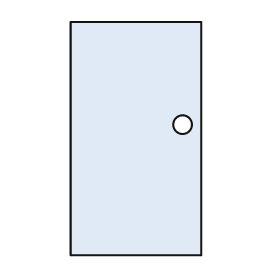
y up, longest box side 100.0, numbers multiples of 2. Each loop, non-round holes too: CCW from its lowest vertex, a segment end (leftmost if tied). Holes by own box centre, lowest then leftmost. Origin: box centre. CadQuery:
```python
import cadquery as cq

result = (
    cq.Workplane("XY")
    .moveTo(-28.0, -50.0)
    .lineTo(28.0, -50.0)
    .lineTo(28.0, 50.0)
    .lineTo(-28.0, 50.0)
    .close()
    .moveTo(20.0, 6.0)
    .circle(4.0)
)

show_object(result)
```